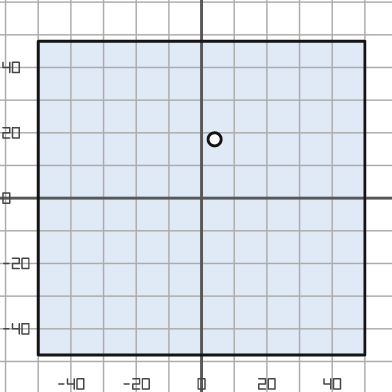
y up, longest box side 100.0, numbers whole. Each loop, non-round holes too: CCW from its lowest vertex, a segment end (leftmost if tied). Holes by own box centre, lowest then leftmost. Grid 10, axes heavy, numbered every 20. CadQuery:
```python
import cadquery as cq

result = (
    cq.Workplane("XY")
    .moveTo(-50.0, -48.0)
    .lineTo(50.0, -48.0)
    .lineTo(50.0, 48.0)
    .lineTo(-50.0, 48.0)
    .close()
    .moveTo(4.0, 18.0)
    .circle(2.0)
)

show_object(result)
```